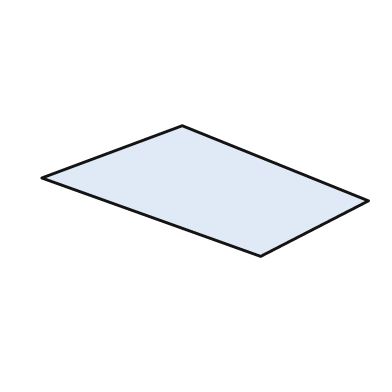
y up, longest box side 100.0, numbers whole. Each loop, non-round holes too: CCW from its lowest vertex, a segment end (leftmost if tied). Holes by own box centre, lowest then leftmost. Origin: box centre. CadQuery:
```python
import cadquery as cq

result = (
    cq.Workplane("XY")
    .moveTo(17.0, -20.0)
    .lineTo(50.0, -3.0)
    .lineTo(-7.0, 20.0)
    .lineTo(-50.0, 4.0)
    .close()
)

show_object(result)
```